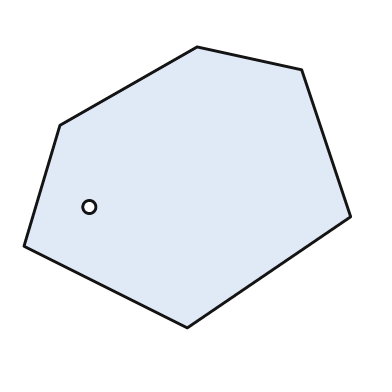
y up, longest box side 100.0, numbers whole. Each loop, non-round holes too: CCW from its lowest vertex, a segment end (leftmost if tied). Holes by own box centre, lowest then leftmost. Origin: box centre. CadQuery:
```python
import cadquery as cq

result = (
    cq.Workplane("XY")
    .moveTo(0.0, -43.0)
    .lineTo(50.0, -9.0)
    .lineTo(35.0, 36.0)
    .lineTo(3.0, 43.0)
    .lineTo(-39.0, 19.0)
    .lineTo(-50.0, -18.0)
    .close()
    .moveTo(-30.0, -6.0)
    .circle(2.0)
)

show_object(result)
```